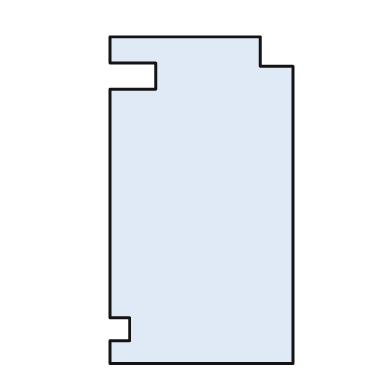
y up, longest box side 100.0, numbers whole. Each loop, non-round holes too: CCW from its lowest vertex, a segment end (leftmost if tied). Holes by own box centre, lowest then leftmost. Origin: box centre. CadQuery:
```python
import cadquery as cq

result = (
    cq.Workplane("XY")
    .moveTo(-28.0, -50.0)
    .lineTo(28.0, -50.0)
    .lineTo(28.0, 41.0)
    .lineTo(18.0, 41.0)
    .lineTo(18.0, 50.0)
    .lineTo(-28.0, 50.0)
    .lineTo(-28.0, 42.0)
    .lineTo(-14.0, 42.0)
    .lineTo(-14.0, 34.0)
    .lineTo(-28.0, 34.0)
    .lineTo(-28.0, -36.0)
    .lineTo(-22.0, -36.0)
    .lineTo(-22.0, -43.0)
    .lineTo(-28.0, -43.0)
    .close()
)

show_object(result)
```